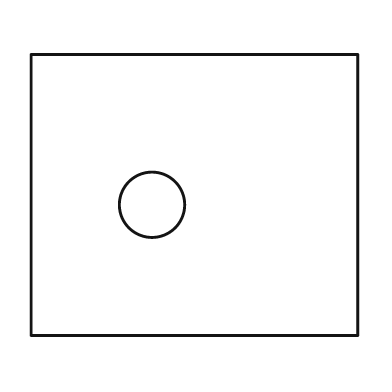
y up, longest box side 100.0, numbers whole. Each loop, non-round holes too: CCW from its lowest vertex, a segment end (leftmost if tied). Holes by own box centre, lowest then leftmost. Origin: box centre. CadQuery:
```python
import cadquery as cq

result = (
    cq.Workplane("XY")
    .moveTo(-50.0, -43.0)
    .lineTo(50.0, -43.0)
    .lineTo(50.0, 43.0)
    .lineTo(-50.0, 43.0)
    .close()
    .moveTo(-13.0, -3.0)
    .circle(10.0)
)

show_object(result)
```